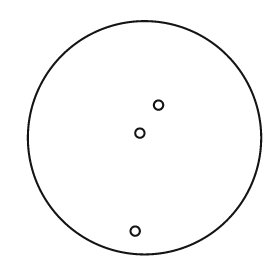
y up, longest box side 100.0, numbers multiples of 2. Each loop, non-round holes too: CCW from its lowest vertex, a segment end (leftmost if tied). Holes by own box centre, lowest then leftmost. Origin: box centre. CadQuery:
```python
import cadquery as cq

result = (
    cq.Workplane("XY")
    .moveTo(0.0, 0.0)
    .circle(50.0)
    .moveTo(-4.0, -40.0)
    .circle(2.0)
    .moveTo(-2.0, 2.0)
    .circle(2.0)
    .moveTo(6.0, 14.0)
    .circle(2.0)
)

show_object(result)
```